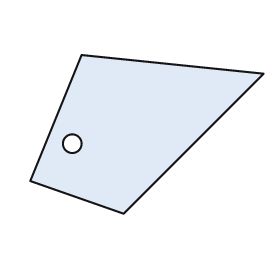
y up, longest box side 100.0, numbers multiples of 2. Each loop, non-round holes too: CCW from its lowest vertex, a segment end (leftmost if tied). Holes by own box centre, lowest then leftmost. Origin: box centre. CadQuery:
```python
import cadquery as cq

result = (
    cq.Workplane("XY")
    .moveTo(-10.0, -34.0)
    .lineTo(50.0, 26.0)
    .lineTo(-28.0, 34.0)
    .lineTo(-50.0, -20.0)
    .close()
    .moveTo(-32.0, -4.0)
    .circle(4.0)
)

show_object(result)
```